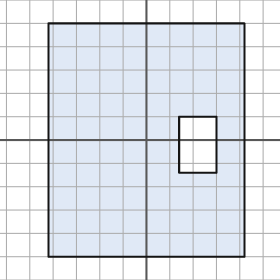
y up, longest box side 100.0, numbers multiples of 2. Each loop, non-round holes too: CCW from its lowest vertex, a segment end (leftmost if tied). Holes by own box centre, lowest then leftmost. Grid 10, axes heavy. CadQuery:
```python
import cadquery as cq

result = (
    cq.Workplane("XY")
    .moveTo(-42.0, -50.0)
    .lineTo(42.0, -50.0)
    .lineTo(42.0, 50.0)
    .lineTo(-42.0, 50.0)
    .close()
    .moveTo(14.0, -14.0)
    .lineTo(30.0, -14.0)
    .lineTo(30.0, 10.0)
    .lineTo(14.0, 10.0)
    .close()
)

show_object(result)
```